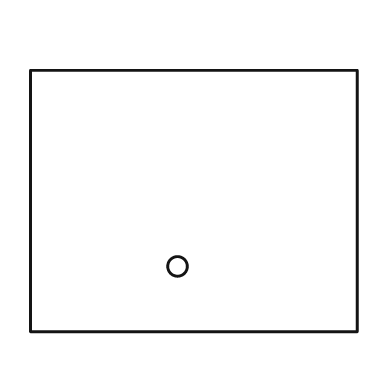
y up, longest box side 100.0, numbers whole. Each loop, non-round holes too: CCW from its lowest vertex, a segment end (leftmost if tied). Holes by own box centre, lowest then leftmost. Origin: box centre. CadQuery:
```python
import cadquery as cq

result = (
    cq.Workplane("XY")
    .moveTo(-50.0, -40.0)
    .lineTo(50.0, -40.0)
    .lineTo(50.0, 40.0)
    .lineTo(-50.0, 40.0)
    .close()
    .moveTo(-5.0, -20.0)
    .circle(3.0)
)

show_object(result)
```